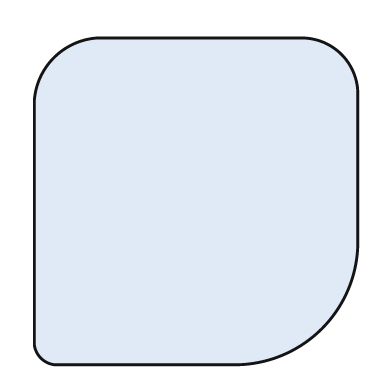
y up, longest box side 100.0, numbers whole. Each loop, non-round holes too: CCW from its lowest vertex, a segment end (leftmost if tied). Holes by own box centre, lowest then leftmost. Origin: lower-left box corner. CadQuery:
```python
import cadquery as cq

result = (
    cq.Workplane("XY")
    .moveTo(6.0, 0.0)
    .lineTo(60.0, 0.0)
    .threePointArc((88.0, 11.0), (99.0, 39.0))
    .lineTo(99.0, 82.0)
    .threePointArc((94.0, 95.0), (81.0, 100.0))
    .lineTo(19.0, 100.0)
    .threePointArc((6.0, 94.0), (0.0, 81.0))
    .lineTo(0.0, 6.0)
    .threePointArc((2.0, 2.0), (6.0, 0.0))
    .close()
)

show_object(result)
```